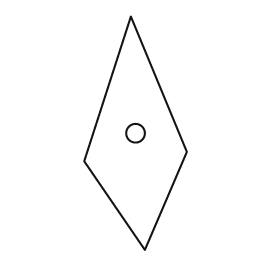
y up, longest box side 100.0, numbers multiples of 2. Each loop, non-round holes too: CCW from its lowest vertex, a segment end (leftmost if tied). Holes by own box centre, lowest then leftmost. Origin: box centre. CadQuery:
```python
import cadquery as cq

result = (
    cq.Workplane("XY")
    .moveTo(4.0, -50.0)
    .lineTo(22.0, -8.0)
    .lineTo(-2.0, 50.0)
    .lineTo(-22.0, -12.0)
    .close()
    .moveTo(0.0, 0.0)
    .circle(4.0)
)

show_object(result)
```